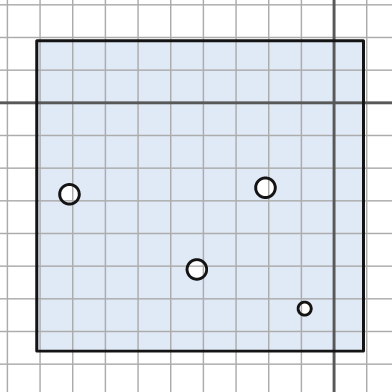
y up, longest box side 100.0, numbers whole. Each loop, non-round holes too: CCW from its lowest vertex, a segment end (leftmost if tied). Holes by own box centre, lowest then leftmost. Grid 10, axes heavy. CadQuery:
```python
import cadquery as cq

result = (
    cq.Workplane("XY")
    .moveTo(-91.0, -76.0)
    .lineTo(9.0, -76.0)
    .lineTo(9.0, 19.0)
    .lineTo(-91.0, 19.0)
    .close()
    .moveTo(-9.0, -63.0)
    .circle(2.0)
    .moveTo(-42.0, -51.0)
    .circle(3.0)
    .moveTo(-81.0, -28.0)
    .circle(3.0)
    .moveTo(-21.0, -26.0)
    .circle(3.0)
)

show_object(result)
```